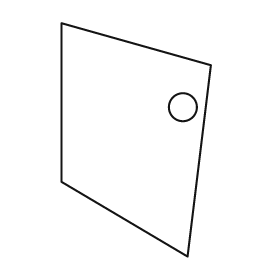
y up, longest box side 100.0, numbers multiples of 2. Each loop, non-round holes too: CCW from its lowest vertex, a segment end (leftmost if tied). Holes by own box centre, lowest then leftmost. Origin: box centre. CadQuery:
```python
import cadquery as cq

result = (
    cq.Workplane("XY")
    .moveTo(22.0, -50.0)
    .lineTo(32.0, 32.0)
    .lineTo(-32.0, 50.0)
    .lineTo(-32.0, -18.0)
    .close()
    .moveTo(20.0, 14.0)
    .circle(6.0)
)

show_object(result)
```